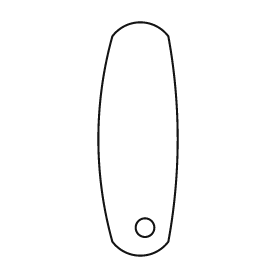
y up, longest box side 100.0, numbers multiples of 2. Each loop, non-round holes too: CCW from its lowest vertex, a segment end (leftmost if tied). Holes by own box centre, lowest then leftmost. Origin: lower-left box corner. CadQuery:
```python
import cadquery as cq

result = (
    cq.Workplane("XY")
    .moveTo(6.0, 6.0)
    .threePointArc((18.0, 0.0), (30.0, 6.0))
    .threePointArc((34.0, 50.0), (30.0, 94.0))
    .threePointArc((18.0, 100.0), (6.0, 94.0))
    .threePointArc((0.0, 50.0), (6.0, 6.0))
    .close()
    .moveTo(20.0, 12.0)
    .circle(4.0)
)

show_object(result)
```